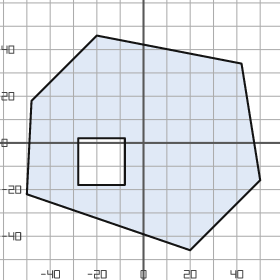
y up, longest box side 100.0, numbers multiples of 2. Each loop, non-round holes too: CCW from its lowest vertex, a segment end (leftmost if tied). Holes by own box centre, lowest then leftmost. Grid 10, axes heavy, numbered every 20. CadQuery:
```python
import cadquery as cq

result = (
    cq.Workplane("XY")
    .moveTo(20.0, -46.0)
    .lineTo(50.0, -16.0)
    .lineTo(42.0, 34.0)
    .lineTo(-20.0, 46.0)
    .lineTo(-48.0, 18.0)
    .lineTo(-50.0, -22.0)
    .close()
    .moveTo(-28.0, -18.0)
    .lineTo(-8.0, -18.0)
    .lineTo(-8.0, 2.0)
    .lineTo(-28.0, 2.0)
    .close()
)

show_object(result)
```